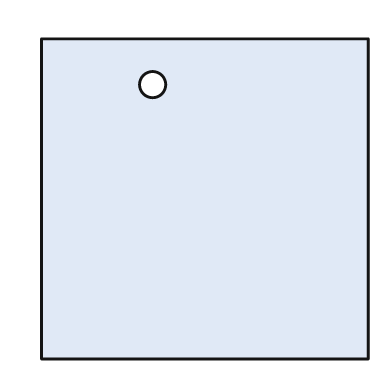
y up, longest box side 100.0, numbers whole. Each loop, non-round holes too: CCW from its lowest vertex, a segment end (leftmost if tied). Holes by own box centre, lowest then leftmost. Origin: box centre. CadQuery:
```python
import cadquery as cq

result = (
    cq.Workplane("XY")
    .moveTo(-50.0, -49.0)
    .lineTo(50.0, -49.0)
    .lineTo(50.0, 49.0)
    .lineTo(-50.0, 49.0)
    .close()
    .moveTo(-16.0, 35.0)
    .circle(4.0)
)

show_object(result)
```